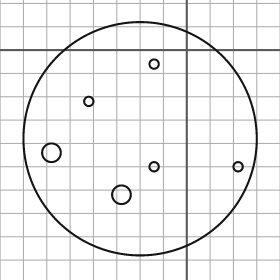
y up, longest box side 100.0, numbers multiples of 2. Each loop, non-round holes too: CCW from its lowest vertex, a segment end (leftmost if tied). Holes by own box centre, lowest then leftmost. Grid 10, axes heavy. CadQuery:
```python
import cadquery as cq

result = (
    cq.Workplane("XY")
    .moveTo(-20.0, -38.0)
    .circle(50.0)
    .moveTo(-28.0, -62.0)
    .circle(4.0)
    .moveTo(-14.0, -50.0)
    .circle(2.0)
    .moveTo(22.0, -50.0)
    .circle(2.0)
    .moveTo(-58.0, -44.0)
    .circle(4.0)
    .moveTo(-42.0, -22.0)
    .circle(2.0)
    .moveTo(-14.0, -6.0)
    .circle(2.0)
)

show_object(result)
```